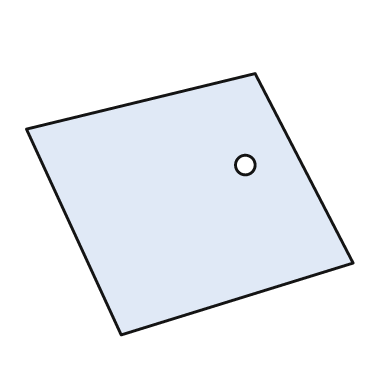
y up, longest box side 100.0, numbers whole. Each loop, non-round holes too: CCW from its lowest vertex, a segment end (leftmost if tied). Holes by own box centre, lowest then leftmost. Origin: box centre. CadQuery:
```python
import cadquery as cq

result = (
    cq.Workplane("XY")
    .moveTo(-21.0, -40.0)
    .lineTo(50.0, -18.0)
    .lineTo(20.0, 40.0)
    .lineTo(-50.0, 23.0)
    .close()
    .moveTo(17.0, 12.0)
    .circle(3.0)
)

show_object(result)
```